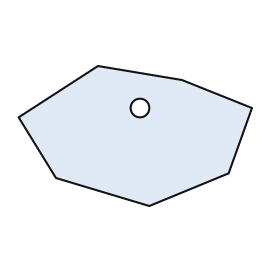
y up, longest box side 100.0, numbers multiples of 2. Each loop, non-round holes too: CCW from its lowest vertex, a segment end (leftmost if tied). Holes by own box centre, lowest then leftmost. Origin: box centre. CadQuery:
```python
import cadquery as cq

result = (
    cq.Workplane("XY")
    .moveTo(6.0, -30.0)
    .lineTo(40.0, -16.0)
    .lineTo(50.0, 12.0)
    .lineTo(20.0, 24.0)
    .lineTo(-16.0, 30.0)
    .lineTo(-50.0, 8.0)
    .lineTo(-34.0, -18.0)
    .close()
    .moveTo(2.0, 12.0)
    .circle(4.0)
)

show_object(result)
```